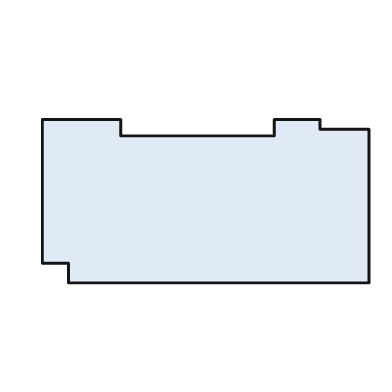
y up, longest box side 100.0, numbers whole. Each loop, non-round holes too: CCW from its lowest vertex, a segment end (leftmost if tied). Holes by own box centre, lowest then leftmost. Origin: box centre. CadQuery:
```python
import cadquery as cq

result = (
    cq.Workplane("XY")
    .moveTo(-42.0, -25.0)
    .lineTo(50.0, -25.0)
    .lineTo(50.0, 22.0)
    .lineTo(35.0, 22.0)
    .lineTo(35.0, 25.0)
    .lineTo(21.0, 25.0)
    .lineTo(21.0, 20.0)
    .lineTo(-26.0, 20.0)
    .lineTo(-26.0, 25.0)
    .lineTo(-50.0, 25.0)
    .lineTo(-50.0, -19.0)
    .lineTo(-42.0, -19.0)
    .close()
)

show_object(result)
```